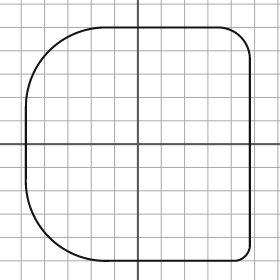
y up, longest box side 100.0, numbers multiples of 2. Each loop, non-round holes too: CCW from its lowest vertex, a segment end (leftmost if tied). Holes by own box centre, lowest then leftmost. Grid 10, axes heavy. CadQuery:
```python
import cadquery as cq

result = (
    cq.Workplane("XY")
    .moveTo(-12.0, -50.0)
    .lineTo(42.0, -50.0)
    .threePointArc((46.0, -48.0), (48.0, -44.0))
    .lineTo(48.0, 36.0)
    .threePointArc((44.0, 46.0), (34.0, 50.0))
    .lineTo(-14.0, 50.0)
    .threePointArc((-38.0, 40.0), (-48.0, 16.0))
    .lineTo(-48.0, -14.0)
    .threePointArc((-38.0, -40.0), (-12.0, -50.0))
    .close()
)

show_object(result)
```